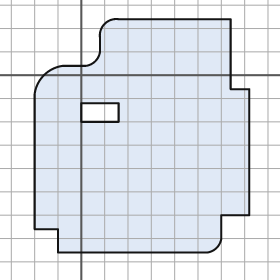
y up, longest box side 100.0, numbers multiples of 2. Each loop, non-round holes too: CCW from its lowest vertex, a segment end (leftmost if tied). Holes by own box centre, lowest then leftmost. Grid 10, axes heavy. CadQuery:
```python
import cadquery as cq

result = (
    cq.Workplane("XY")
    .moveTo(-10.0, -76.0)
    .lineTo(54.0, -76.0)
    .threePointArc((58.0, -74.0), (60.0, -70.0))
    .lineTo(60.0, -60.0)
    .lineTo(72.0, -60.0)
    .lineTo(72.0, -6.0)
    .lineTo(64.0, -6.0)
    .lineTo(64.0, 24.0)
    .lineTo(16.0, 24.0)
    .threePointArc((10.0, 22.0), (8.0, 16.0))
    .lineTo(8.0, 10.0)
    .threePointArc((6.0, 6.0), (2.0, 4.0))
    .lineTo(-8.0, 4.0)
    .threePointArc((-16.0, 0.0), (-20.0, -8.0))
    .lineTo(-20.0, -66.0)
    .lineTo(-10.0, -66.0)
    .close()
    .moveTo(0.0, -20.0)
    .lineTo(16.0, -20.0)
    .lineTo(16.0, -12.0)
    .lineTo(0.0, -12.0)
    .close()
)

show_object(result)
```